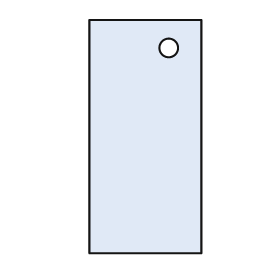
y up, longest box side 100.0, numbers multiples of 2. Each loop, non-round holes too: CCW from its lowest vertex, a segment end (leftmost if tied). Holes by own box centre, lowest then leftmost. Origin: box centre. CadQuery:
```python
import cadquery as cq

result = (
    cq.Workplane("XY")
    .moveTo(-24.0, -50.0)
    .lineTo(24.0, -50.0)
    .lineTo(24.0, 50.0)
    .lineTo(-24.0, 50.0)
    .close()
    .moveTo(10.0, 38.0)
    .circle(4.0)
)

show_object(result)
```